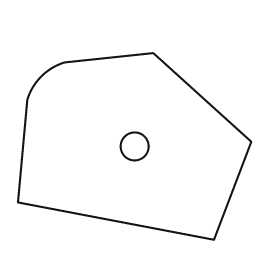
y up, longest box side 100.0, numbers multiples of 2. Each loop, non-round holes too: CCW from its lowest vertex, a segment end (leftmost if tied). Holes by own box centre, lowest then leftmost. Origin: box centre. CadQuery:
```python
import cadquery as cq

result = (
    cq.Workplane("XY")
    .moveTo(34.0, -40.0)
    .lineTo(50.0, 2.0)
    .lineTo(8.0, 40.0)
    .lineTo(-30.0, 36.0)
    .threePointArc((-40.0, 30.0), (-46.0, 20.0))
    .lineTo(-50.0, -24.0)
    .close()
    .moveTo(0.0, 0.0)
    .circle(6.0)
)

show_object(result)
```